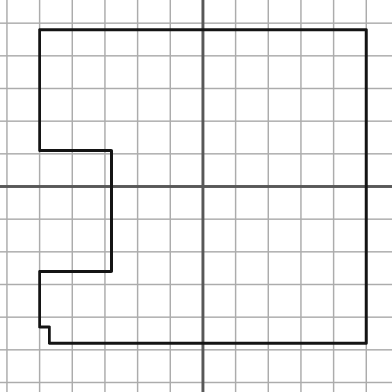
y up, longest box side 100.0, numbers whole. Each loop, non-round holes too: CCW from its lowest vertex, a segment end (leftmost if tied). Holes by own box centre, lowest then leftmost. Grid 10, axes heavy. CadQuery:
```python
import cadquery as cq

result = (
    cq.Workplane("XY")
    .moveTo(-47.0, -48.0)
    .lineTo(50.0, -48.0)
    .lineTo(50.0, 48.0)
    .lineTo(-50.0, 48.0)
    .lineTo(-50.0, 11.0)
    .lineTo(-28.0, 11.0)
    .lineTo(-28.0, -26.0)
    .lineTo(-50.0, -26.0)
    .lineTo(-50.0, -43.0)
    .lineTo(-47.0, -43.0)
    .close()
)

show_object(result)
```